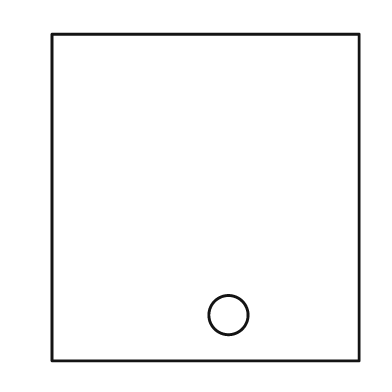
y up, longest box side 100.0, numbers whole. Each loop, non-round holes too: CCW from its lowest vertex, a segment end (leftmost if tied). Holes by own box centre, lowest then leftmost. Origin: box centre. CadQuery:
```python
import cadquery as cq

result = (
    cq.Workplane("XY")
    .moveTo(-47.0, -50.0)
    .lineTo(47.0, -50.0)
    .lineTo(47.0, 50.0)
    .lineTo(-47.0, 50.0)
    .close()
    .moveTo(7.0, -36.0)
    .circle(6.0)
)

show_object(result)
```